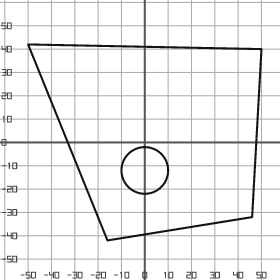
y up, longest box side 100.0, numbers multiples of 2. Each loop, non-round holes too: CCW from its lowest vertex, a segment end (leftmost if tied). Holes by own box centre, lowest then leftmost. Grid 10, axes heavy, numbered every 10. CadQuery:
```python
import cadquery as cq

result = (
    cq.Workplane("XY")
    .moveTo(-16.0, -42.0)
    .lineTo(46.0, -32.0)
    .lineTo(50.0, 40.0)
    .lineTo(-50.0, 42.0)
    .close()
    .moveTo(0.0, -12.0)
    .circle(10.0)
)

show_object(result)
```